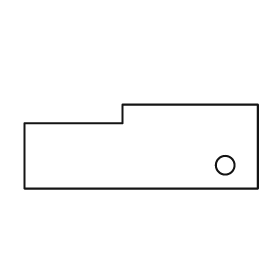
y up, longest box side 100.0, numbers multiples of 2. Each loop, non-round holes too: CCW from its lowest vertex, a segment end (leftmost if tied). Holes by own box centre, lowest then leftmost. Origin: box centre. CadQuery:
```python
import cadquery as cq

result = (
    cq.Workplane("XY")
    .moveTo(-50.0, -18.0)
    .lineTo(50.0, -18.0)
    .lineTo(50.0, 18.0)
    .lineTo(-8.0, 18.0)
    .lineTo(-8.0, 10.0)
    .lineTo(-50.0, 10.0)
    .close()
    .moveTo(36.0, -8.0)
    .circle(4.0)
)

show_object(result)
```